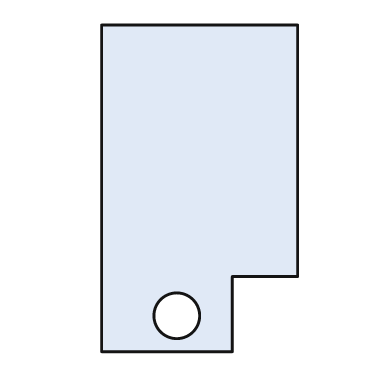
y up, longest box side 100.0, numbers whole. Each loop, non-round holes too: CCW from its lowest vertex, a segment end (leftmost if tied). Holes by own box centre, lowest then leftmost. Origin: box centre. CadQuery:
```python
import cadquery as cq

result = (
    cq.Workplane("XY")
    .moveTo(-30.0, -50.0)
    .lineTo(10.0, -50.0)
    .lineTo(10.0, -27.0)
    .lineTo(30.0, -27.0)
    .lineTo(30.0, 50.0)
    .lineTo(-30.0, 50.0)
    .close()
    .moveTo(-7.0, -39.0)
    .circle(7.0)
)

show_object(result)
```